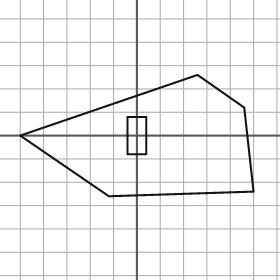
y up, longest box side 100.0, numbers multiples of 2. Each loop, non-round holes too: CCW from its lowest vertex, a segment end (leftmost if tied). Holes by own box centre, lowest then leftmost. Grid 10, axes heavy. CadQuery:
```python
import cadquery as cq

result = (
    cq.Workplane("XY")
    .moveTo(-12.0, -26.0)
    .lineTo(50.0, -24.0)
    .lineTo(46.0, 12.0)
    .lineTo(26.0, 26.0)
    .lineTo(-50.0, 0.0)
    .close()
    .moveTo(-4.0, -8.0)
    .lineTo(4.0, -8.0)
    .lineTo(4.0, 8.0)
    .lineTo(-4.0, 8.0)
    .close()
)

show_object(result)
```